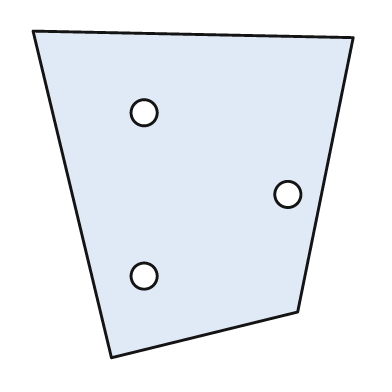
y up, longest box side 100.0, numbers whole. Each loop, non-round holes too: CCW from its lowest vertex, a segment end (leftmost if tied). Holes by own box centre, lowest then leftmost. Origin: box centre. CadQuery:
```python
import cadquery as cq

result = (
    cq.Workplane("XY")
    .moveTo(-25.0, -50.0)
    .lineTo(32.0, -36.0)
    .lineTo(49.0, 48.0)
    .lineTo(-49.0, 50.0)
    .close()
    .moveTo(-15.0, -25.0)
    .circle(4.0)
    .moveTo(29.0, 0.0)
    .circle(4.0)
    .moveTo(-15.0, 25.0)
    .circle(4.0)
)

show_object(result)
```